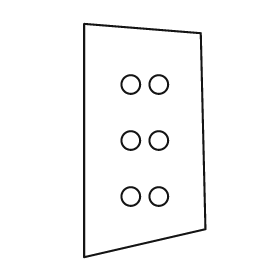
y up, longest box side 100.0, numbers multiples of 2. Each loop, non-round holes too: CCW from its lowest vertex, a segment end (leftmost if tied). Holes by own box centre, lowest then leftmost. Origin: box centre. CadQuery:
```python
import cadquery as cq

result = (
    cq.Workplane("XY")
    .moveTo(-26.0, -50.0)
    .lineTo(26.0, -38.0)
    .lineTo(24.0, 46.0)
    .lineTo(-26.0, 50.0)
    .close()
    .moveTo(-6.0, -24.0)
    .circle(4.0)
    .moveTo(6.0, -24.0)
    .circle(4.0)
    .moveTo(-6.0, 0.0)
    .circle(4.0)
    .moveTo(6.0, 0.0)
    .circle(4.0)
    .moveTo(-6.0, 24.0)
    .circle(4.0)
    .moveTo(6.0, 24.0)
    .circle(4.0)
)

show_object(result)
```